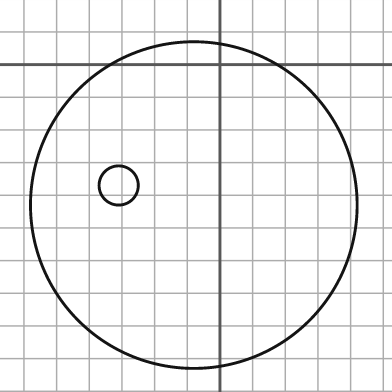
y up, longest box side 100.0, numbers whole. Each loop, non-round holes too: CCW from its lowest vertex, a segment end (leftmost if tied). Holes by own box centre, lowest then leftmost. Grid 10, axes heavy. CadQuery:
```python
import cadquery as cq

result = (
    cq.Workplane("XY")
    .moveTo(-8.0, -43.0)
    .circle(50.0)
    .moveTo(-31.0, -37.0)
    .circle(6.0)
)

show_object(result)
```